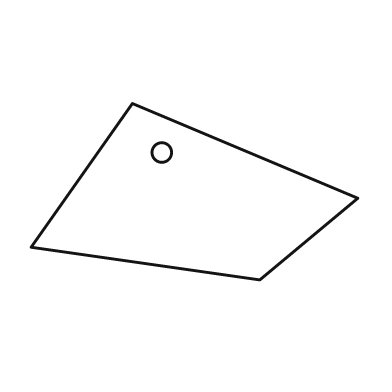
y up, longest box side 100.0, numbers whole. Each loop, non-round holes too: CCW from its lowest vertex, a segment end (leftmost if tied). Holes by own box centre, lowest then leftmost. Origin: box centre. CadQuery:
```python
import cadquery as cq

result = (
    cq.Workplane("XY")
    .moveTo(20.0, -27.0)
    .lineTo(50.0, -2.0)
    .lineTo(-19.0, 27.0)
    .lineTo(-50.0, -17.0)
    .close()
    .moveTo(-10.0, 12.0)
    .circle(3.0)
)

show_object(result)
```